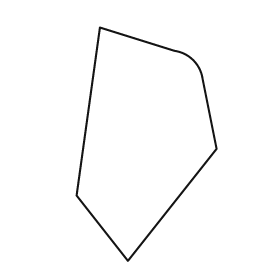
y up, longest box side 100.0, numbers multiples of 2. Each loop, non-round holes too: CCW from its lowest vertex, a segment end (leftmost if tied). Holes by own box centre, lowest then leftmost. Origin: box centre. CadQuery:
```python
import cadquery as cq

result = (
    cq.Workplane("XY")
    .moveTo(-8.0, -50.0)
    .lineTo(30.0, -2.0)
    .lineTo(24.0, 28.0)
    .threePointArc((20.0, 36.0), (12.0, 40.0))
    .lineTo(-20.0, 50.0)
    .lineTo(-30.0, -22.0)
    .close()
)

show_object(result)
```